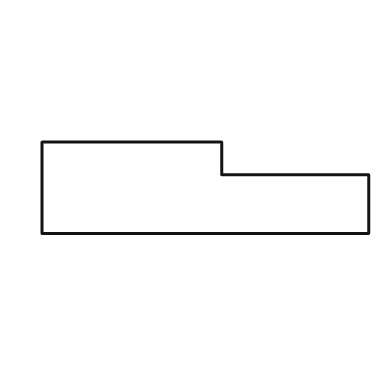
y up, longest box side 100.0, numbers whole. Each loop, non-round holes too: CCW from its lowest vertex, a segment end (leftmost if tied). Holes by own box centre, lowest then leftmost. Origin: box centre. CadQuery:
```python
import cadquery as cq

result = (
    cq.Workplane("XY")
    .moveTo(-50.0, -14.0)
    .lineTo(50.0, -14.0)
    .lineTo(50.0, 4.0)
    .lineTo(5.0, 4.0)
    .lineTo(5.0, 14.0)
    .lineTo(-50.0, 14.0)
    .close()
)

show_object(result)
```